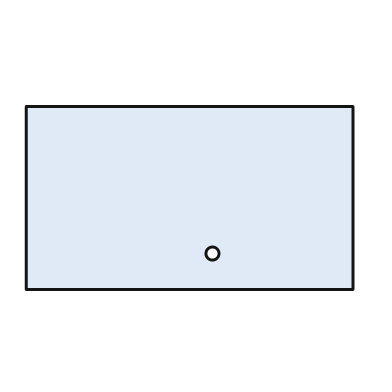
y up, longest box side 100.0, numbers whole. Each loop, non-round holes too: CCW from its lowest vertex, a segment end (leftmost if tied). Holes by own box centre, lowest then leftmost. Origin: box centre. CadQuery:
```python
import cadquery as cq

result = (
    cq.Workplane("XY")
    .moveTo(-50.0, -28.0)
    .lineTo(50.0, -28.0)
    .lineTo(50.0, 28.0)
    .lineTo(-50.0, 28.0)
    .close()
    .moveTo(7.0, -17.0)
    .circle(2.0)
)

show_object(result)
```